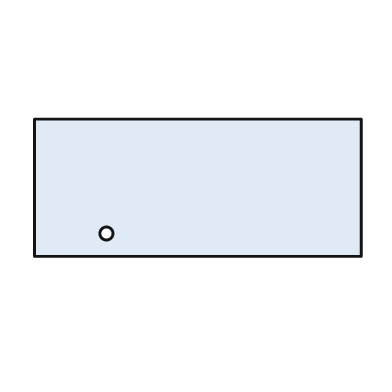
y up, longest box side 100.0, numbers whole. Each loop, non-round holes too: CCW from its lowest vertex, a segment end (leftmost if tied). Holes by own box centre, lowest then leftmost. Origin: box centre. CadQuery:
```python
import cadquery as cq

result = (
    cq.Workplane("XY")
    .moveTo(-50.0, -21.0)
    .lineTo(50.0, -21.0)
    .lineTo(50.0, 21.0)
    .lineTo(-50.0, 21.0)
    .close()
    .moveTo(-28.0, -14.0)
    .circle(2.0)
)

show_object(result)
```